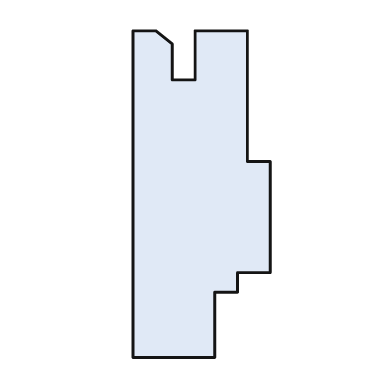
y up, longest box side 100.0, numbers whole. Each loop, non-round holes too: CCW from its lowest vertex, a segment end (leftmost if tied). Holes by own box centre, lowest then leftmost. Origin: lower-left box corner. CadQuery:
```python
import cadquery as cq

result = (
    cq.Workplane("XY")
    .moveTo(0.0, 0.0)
    .lineTo(25.0, 0.0)
    .lineTo(25.0, 20.0)
    .lineTo(32.0, 20.0)
    .lineTo(32.0, 26.0)
    .lineTo(42.0, 26.0)
    .lineTo(42.0, 60.0)
    .lineTo(35.0, 60.0)
    .lineTo(35.0, 100.0)
    .lineTo(19.0, 100.0)
    .lineTo(19.0, 85.0)
    .lineTo(12.0, 85.0)
    .lineTo(12.0, 96.0)
    .lineTo(7.0, 100.0)
    .lineTo(0.0, 100.0)
    .close()
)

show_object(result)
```